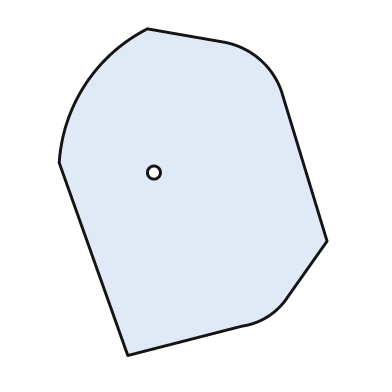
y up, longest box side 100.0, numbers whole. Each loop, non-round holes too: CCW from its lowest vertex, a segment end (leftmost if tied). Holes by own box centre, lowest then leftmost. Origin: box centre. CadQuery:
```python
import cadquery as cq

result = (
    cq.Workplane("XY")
    .moveTo(-20.0, -50.0)
    .lineTo(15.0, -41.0)
    .threePointArc((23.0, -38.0), (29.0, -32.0))
    .lineTo(41.0, -15.0)
    .lineTo(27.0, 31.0)
    .threePointArc((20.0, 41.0), (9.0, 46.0))
    .lineTo(-14.0, 50.0)
    .threePointArc((-33.0, 33.0), (-41.0, 9.0))
    .close()
    .moveTo(-12.0, 6.0)
    .circle(2.0)
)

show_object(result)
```